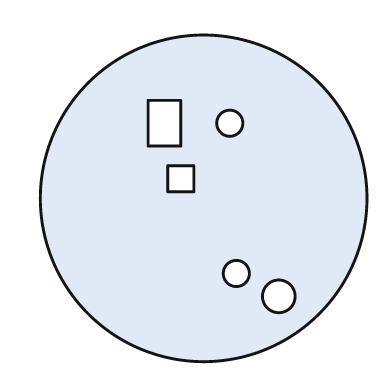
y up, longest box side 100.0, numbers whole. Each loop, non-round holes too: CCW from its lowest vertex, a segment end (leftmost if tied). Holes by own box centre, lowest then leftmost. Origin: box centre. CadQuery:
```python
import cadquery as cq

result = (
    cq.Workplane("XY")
    .moveTo(0.0, 0.0)
    .circle(50.0)
    .moveTo(23.0, -30.0)
    .circle(5.0)
    .moveTo(10.0, -23.0)
    .circle(4.0)
    .moveTo(-11.0, 2.0)
    .lineTo(-3.0, 2.0)
    .lineTo(-3.0, 10.0)
    .lineTo(-11.0, 10.0)
    .close()
    .moveTo(-17.0, 16.0)
    .lineTo(-7.0, 16.0)
    .lineTo(-7.0, 30.0)
    .lineTo(-17.0, 30.0)
    .close()
    .moveTo(8.0, 23.0)
    .circle(4.0)
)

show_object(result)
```